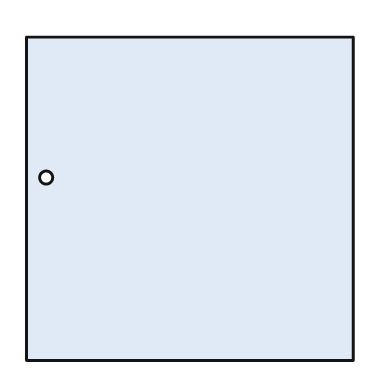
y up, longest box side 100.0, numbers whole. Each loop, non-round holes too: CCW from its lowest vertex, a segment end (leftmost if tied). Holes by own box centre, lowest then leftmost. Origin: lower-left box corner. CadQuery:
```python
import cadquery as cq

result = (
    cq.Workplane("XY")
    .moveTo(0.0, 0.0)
    .lineTo(100.0, 0.0)
    .lineTo(100.0, 99.0)
    .lineTo(0.0, 99.0)
    .close()
    .moveTo(6.0, 56.0)
    .circle(2.0)
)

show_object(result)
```